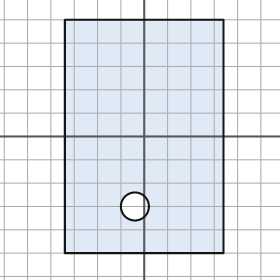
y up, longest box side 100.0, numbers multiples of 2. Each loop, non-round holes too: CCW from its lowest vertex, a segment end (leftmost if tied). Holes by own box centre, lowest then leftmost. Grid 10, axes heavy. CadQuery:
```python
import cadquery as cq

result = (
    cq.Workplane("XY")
    .moveTo(-34.0, -50.0)
    .lineTo(34.0, -50.0)
    .lineTo(34.0, 50.0)
    .lineTo(-34.0, 50.0)
    .close()
    .moveTo(-4.0, -30.0)
    .circle(6.0)
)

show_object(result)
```